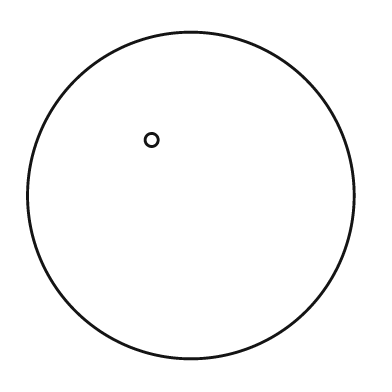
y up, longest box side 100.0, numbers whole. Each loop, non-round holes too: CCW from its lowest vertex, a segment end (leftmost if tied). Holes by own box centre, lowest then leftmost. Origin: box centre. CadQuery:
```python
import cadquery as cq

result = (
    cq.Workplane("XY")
    .moveTo(0.0, 0.0)
    .circle(50.0)
    .moveTo(-12.0, 17.0)
    .circle(2.0)
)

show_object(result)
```